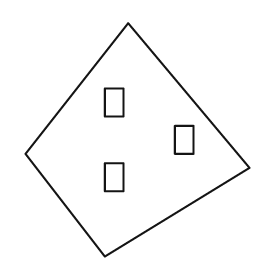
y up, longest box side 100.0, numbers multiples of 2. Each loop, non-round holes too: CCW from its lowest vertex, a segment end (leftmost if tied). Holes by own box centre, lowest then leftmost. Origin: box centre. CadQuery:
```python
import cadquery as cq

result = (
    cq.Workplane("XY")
    .moveTo(-14.0, -50.0)
    .lineTo(48.0, -12.0)
    .lineTo(-4.0, 50.0)
    .lineTo(-48.0, -6.0)
    .close()
    .moveTo(-14.0, -22.0)
    .lineTo(-6.0, -22.0)
    .lineTo(-6.0, -10.0)
    .lineTo(-14.0, -10.0)
    .close()
    .moveTo(16.0, -6.0)
    .lineTo(24.0, -6.0)
    .lineTo(24.0, 6.0)
    .lineTo(16.0, 6.0)
    .close()
    .moveTo(-14.0, 10.0)
    .lineTo(-6.0, 10.0)
    .lineTo(-6.0, 22.0)
    .lineTo(-14.0, 22.0)
    .close()
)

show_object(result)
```